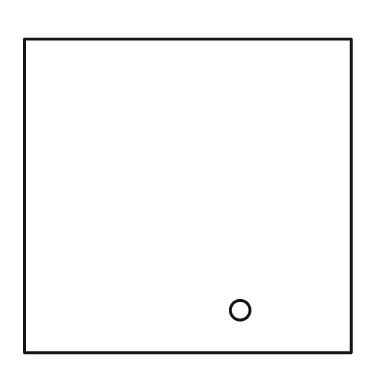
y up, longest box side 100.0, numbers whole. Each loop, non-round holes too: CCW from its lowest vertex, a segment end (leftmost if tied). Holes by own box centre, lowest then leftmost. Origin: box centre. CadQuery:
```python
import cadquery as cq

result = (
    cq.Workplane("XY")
    .moveTo(-50.0, -48.0)
    .lineTo(50.0, -48.0)
    .lineTo(50.0, 48.0)
    .lineTo(-50.0, 48.0)
    .close()
    .moveTo(16.0, -35.0)
    .circle(3.0)
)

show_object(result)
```